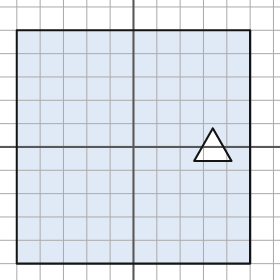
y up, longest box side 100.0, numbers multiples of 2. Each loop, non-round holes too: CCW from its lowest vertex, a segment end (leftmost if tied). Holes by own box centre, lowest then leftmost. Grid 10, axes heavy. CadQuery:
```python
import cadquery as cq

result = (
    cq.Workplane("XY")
    .moveTo(-50.0, -50.0)
    .lineTo(50.0, -50.0)
    .lineTo(50.0, 50.0)
    .lineTo(-50.0, 50.0)
    .close()
    .moveTo(26.0, -6.0)
    .lineTo(42.0, -6.0)
    .lineTo(34.0, 8.0)
    .close()
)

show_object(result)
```